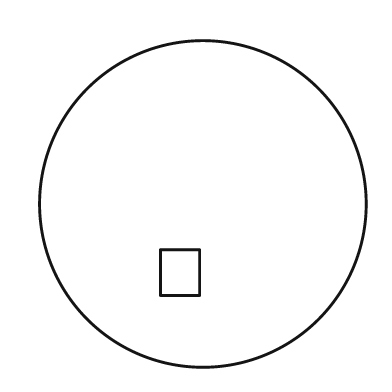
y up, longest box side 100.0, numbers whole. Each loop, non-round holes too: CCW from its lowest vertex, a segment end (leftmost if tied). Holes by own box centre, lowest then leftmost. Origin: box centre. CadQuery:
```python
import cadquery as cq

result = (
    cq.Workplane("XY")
    .moveTo(0.0, 0.0)
    .circle(50.0)
    .moveTo(-13.0, -28.0)
    .lineTo(-1.0, -28.0)
    .lineTo(-1.0, -14.0)
    .lineTo(-13.0, -14.0)
    .close()
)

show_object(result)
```